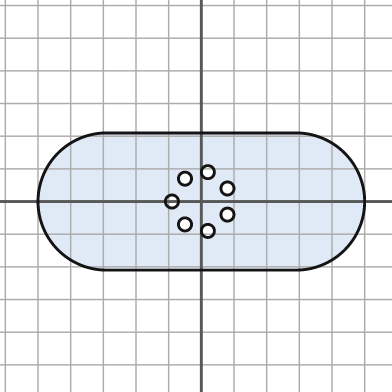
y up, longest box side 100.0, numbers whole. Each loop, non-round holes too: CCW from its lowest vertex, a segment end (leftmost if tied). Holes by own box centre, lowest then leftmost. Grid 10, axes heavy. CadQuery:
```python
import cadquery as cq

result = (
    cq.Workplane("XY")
    .moveTo(-29.0, -21.0)
    .lineTo(29.0, -21.0)
    .threePointArc((50.0, 0.0), (29.0, 21.0))
    .lineTo(-29.0, 21.0)
    .threePointArc((-50.0, 0.0), (-29.0, -21.0))
    .close()
    .moveTo(2.0, -9.0)
    .circle(2.0)
    .moveTo(-5.0, -7.0)
    .circle(2.0)
    .moveTo(8.0, -4.0)
    .circle(2.0)
    .moveTo(-9.0, 0.0)
    .circle(2.0)
    .moveTo(8.0, 4.0)
    .circle(2.0)
    .moveTo(-5.0, 7.0)
    .circle(2.0)
    .moveTo(2.0, 9.0)
    .circle(2.0)
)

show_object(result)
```